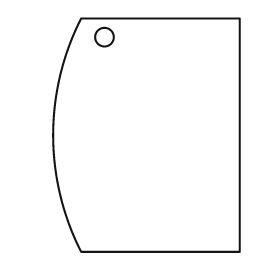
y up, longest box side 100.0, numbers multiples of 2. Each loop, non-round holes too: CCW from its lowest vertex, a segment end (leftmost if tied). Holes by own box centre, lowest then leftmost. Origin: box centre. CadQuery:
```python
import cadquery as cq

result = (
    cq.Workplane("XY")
    .moveTo(-28.0, -50.0)
    .lineTo(40.0, -50.0)
    .lineTo(40.0, 50.0)
    .lineTo(-28.0, 50.0)
    .threePointArc((-40.0, 0.0), (-28.0, -50.0))
    .close()
    .moveTo(-18.0, 42.0)
    .circle(4.0)
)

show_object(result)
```